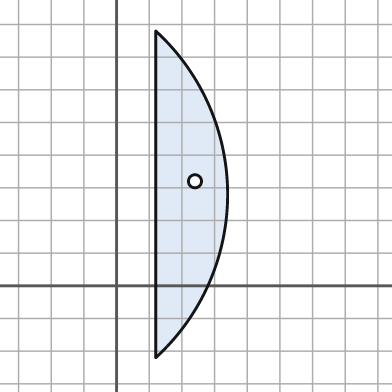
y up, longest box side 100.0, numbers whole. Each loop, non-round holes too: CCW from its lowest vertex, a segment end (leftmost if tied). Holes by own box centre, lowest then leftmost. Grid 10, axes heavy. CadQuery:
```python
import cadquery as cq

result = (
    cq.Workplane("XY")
    .moveTo(12.0, -22.0)
    .threePointArc((34.0, 28.0), (12.0, 78.0))
    .close()
    .moveTo(24.0, 32.0)
    .circle(2.0)
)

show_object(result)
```